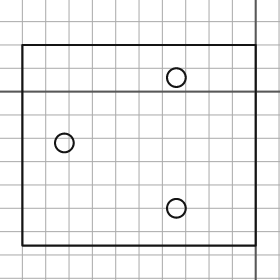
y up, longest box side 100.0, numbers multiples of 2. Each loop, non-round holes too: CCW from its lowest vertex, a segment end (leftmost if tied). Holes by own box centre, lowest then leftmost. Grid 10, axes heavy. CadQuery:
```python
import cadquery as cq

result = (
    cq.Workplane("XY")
    .moveTo(-100.0, -66.0)
    .lineTo(0.0, -66.0)
    .lineTo(0.0, 20.0)
    .lineTo(-100.0, 20.0)
    .close()
    .moveTo(-34.0, -50.0)
    .circle(4.0)
    .moveTo(-82.0, -22.0)
    .circle(4.0)
    .moveTo(-34.0, 6.0)
    .circle(4.0)
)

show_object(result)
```